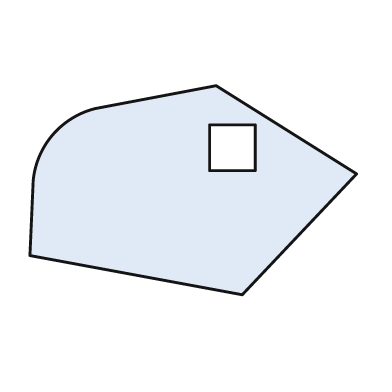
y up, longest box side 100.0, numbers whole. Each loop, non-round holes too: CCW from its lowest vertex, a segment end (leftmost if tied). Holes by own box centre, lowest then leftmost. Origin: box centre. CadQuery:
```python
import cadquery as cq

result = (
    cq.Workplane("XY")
    .moveTo(15.0, -32.0)
    .lineTo(50.0, 5.0)
    .lineTo(7.0, 32.0)
    .lineTo(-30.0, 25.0)
    .threePointArc((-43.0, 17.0), (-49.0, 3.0))
    .lineTo(-50.0, -20.0)
    .close()
    .moveTo(5.0, 6.0)
    .lineTo(19.0, 6.0)
    .lineTo(19.0, 20.0)
    .lineTo(5.0, 20.0)
    .close()
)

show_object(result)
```